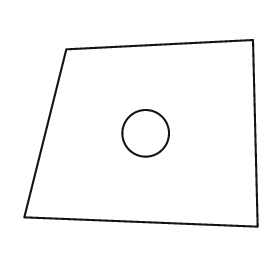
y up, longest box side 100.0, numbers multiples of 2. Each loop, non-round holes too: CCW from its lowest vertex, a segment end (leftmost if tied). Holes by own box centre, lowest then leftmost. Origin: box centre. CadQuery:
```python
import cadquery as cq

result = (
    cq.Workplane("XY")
    .moveTo(50.0, -40.0)
    .lineTo(48.0, 40.0)
    .lineTo(-32.0, 36.0)
    .lineTo(-50.0, -36.0)
    .close()
    .moveTo(2.0, 0.0)
    .circle(10.0)
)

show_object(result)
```